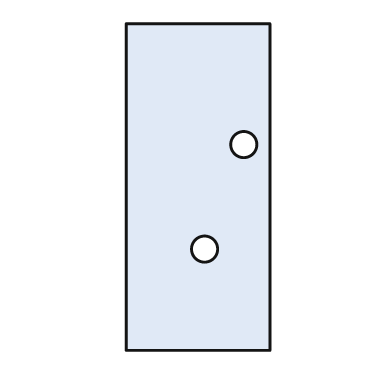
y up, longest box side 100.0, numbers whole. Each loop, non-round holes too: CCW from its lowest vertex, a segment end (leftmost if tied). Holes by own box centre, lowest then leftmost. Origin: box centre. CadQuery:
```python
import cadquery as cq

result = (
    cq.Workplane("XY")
    .moveTo(-22.0, -50.0)
    .lineTo(22.0, -50.0)
    .lineTo(22.0, 50.0)
    .lineTo(-22.0, 50.0)
    .close()
    .moveTo(2.0, -19.0)
    .circle(4.0)
    .moveTo(14.0, 13.0)
    .circle(4.0)
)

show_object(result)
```